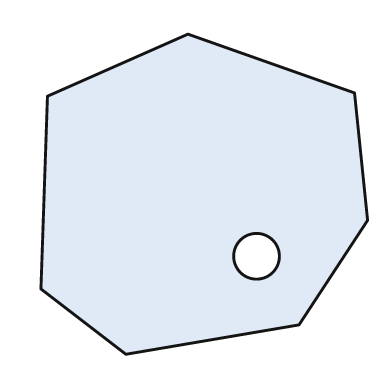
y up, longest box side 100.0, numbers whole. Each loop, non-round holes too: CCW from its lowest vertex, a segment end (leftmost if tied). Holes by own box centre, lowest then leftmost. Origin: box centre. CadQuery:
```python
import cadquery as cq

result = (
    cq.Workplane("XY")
    .moveTo(-24.0, -49.0)
    .lineTo(29.0, -40.0)
    .lineTo(50.0, -8.0)
    .lineTo(46.0, 31.0)
    .lineTo(-5.0, 49.0)
    .lineTo(-48.0, 30.0)
    .lineTo(-50.0, -29.0)
    .close()
    .moveTo(16.0, -19.0)
    .circle(7.0)
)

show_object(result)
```